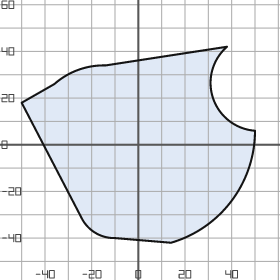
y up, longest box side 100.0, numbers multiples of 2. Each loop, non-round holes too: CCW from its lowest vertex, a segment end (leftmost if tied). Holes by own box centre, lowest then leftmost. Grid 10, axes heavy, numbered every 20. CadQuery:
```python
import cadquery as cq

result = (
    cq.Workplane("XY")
    .moveTo(14.0, -42.0)
    .threePointArc((40.0, -24.0), (50.0, 6.0))
    .threePointArc((32.0, 20.0), (38.0, 42.0))
    .lineTo(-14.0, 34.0)
    .threePointArc((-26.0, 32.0), (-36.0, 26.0))
    .lineTo(-50.0, 18.0)
    .lineTo(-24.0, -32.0)
    .threePointArc((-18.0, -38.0), (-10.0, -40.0))
    .close()
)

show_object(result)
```